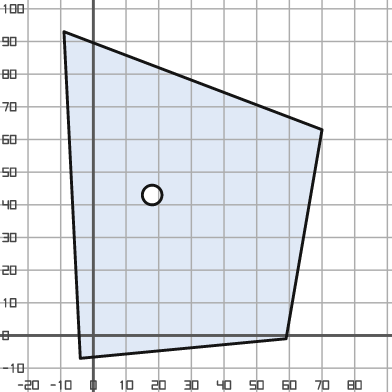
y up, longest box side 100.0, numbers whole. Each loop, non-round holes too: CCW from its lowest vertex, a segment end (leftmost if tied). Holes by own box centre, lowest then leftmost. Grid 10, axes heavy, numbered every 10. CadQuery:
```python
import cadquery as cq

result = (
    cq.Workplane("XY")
    .moveTo(-4.0, -7.0)
    .lineTo(59.0, -1.0)
    .lineTo(70.0, 63.0)
    .lineTo(-9.0, 93.0)
    .close()
    .moveTo(18.0, 43.0)
    .circle(3.0)
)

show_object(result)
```